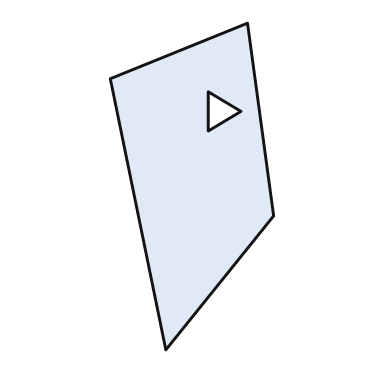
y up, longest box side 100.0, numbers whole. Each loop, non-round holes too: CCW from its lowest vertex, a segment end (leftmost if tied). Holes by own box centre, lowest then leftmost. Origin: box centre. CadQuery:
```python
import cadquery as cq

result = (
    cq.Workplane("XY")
    .moveTo(-8.0, -50.0)
    .lineTo(25.0, -9.0)
    .lineTo(17.0, 50.0)
    .lineTo(-25.0, 33.0)
    .close()
    .moveTo(5.0, 17.0)
    .lineTo(15.0, 23.0)
    .lineTo(5.0, 29.0)
    .close()
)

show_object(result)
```